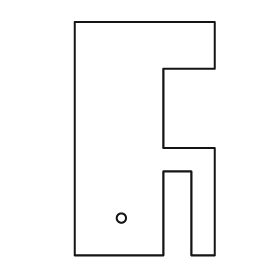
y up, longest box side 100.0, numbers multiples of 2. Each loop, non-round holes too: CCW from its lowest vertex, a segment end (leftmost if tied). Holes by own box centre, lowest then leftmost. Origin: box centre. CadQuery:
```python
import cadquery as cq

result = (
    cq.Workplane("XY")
    .moveTo(-30.0, -50.0)
    .lineTo(8.0, -50.0)
    .lineTo(8.0, -14.0)
    .lineTo(20.0, -14.0)
    .lineTo(20.0, -50.0)
    .lineTo(30.0, -50.0)
    .lineTo(30.0, -4.0)
    .lineTo(8.0, -4.0)
    .lineTo(8.0, 30.0)
    .lineTo(30.0, 30.0)
    .lineTo(30.0, 50.0)
    .lineTo(-30.0, 50.0)
    .close()
    .moveTo(-10.0, -34.0)
    .circle(2.0)
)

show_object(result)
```